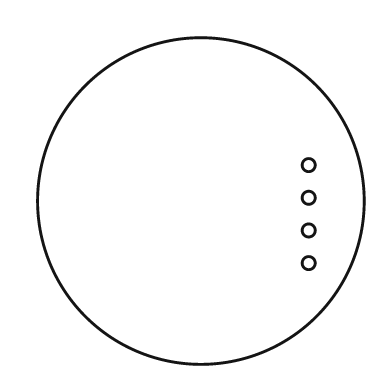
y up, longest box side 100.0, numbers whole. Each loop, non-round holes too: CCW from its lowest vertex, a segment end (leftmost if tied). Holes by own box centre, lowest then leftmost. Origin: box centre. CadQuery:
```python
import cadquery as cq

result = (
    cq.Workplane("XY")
    .moveTo(0.0, 0.0)
    .circle(50.0)
    .moveTo(33.0, -19.0)
    .circle(2.0)
    .moveTo(33.0, -9.0)
    .circle(2.0)
    .moveTo(33.0, 1.0)
    .circle(2.0)
    .moveTo(33.0, 11.0)
    .circle(2.0)
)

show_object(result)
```